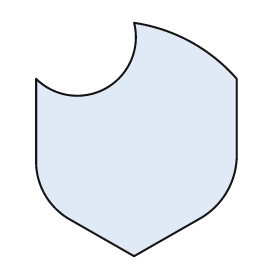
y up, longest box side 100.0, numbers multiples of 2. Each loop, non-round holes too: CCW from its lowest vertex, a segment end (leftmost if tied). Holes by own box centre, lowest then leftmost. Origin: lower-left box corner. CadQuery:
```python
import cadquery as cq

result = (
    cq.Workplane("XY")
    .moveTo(42.0, 0.0)
    .lineTo(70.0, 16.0)
    .threePointArc((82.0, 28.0), (86.0, 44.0))
    .lineTo(86.0, 76.0)
    .threePointArc((66.0, 92.0), (42.0, 100.0))
    .threePointArc((30.0, 72.0), (0.0, 76.0))
    .lineTo(0.0, 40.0)
    .threePointArc((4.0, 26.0), (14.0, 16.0))
    .close()
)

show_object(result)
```